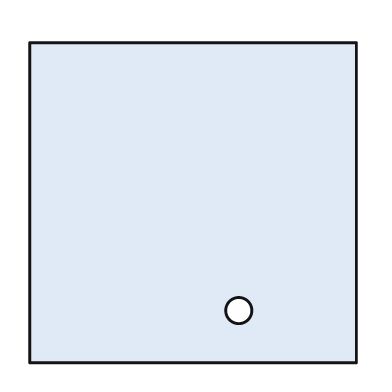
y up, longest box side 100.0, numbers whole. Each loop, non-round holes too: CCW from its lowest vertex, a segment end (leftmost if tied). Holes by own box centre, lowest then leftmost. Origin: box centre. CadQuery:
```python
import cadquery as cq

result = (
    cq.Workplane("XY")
    .moveTo(-50.0, -49.0)
    .lineTo(50.0, -49.0)
    .lineTo(50.0, 49.0)
    .lineTo(-50.0, 49.0)
    .close()
    .moveTo(14.0, -33.0)
    .circle(4.0)
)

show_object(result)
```